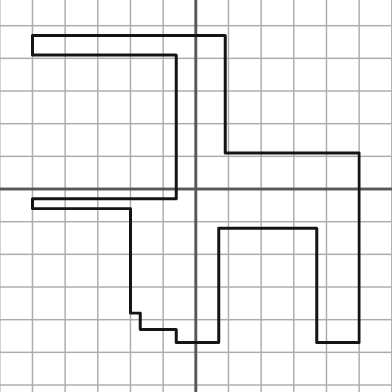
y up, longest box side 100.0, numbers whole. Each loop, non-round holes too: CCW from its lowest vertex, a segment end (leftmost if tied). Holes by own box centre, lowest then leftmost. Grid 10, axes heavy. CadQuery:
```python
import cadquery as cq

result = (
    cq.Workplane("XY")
    .moveTo(-6.0, -47.0)
    .lineTo(7.0, -47.0)
    .lineTo(7.0, -12.0)
    .lineTo(37.0, -12.0)
    .lineTo(37.0, -47.0)
    .lineTo(50.0, -47.0)
    .lineTo(50.0, 11.0)
    .lineTo(9.0, 11.0)
    .lineTo(9.0, 47.0)
    .lineTo(-50.0, 47.0)
    .lineTo(-50.0, 41.0)
    .lineTo(-6.0, 41.0)
    .lineTo(-6.0, -3.0)
    .lineTo(-50.0, -3.0)
    .lineTo(-50.0, -6.0)
    .lineTo(-20.0, -6.0)
    .lineTo(-20.0, -38.0)
    .lineTo(-17.0, -38.0)
    .lineTo(-17.0, -43.0)
    .lineTo(-6.0, -43.0)
    .close()
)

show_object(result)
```